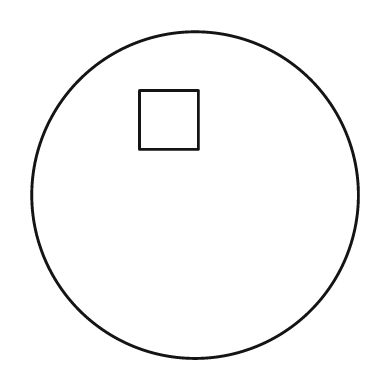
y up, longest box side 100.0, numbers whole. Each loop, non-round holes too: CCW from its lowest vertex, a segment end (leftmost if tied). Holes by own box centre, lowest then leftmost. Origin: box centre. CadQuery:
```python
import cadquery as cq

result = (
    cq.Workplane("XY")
    .moveTo(0.0, 0.0)
    .circle(50.0)
    .moveTo(-17.0, 14.0)
    .lineTo(1.0, 14.0)
    .lineTo(1.0, 32.0)
    .lineTo(-17.0, 32.0)
    .close()
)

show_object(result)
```